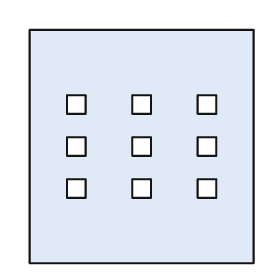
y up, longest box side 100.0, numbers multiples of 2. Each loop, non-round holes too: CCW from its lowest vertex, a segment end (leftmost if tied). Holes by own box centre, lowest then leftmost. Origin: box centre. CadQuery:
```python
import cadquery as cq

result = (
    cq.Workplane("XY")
    .moveTo(-48.0, -50.0)
    .lineTo(48.0, -50.0)
    .lineTo(48.0, 50.0)
    .lineTo(-48.0, 50.0)
    .close()
    .moveTo(-32.0, -22.0)
    .lineTo(-24.0, -22.0)
    .lineTo(-24.0, -14.0)
    .lineTo(-32.0, -14.0)
    .close()
    .moveTo(-4.0, -22.0)
    .lineTo(4.0, -22.0)
    .lineTo(4.0, -14.0)
    .lineTo(-4.0, -14.0)
    .close()
    .moveTo(24.0, -22.0)
    .lineTo(32.0, -22.0)
    .lineTo(32.0, -14.0)
    .lineTo(24.0, -14.0)
    .close()
    .moveTo(-32.0, -4.0)
    .lineTo(-24.0, -4.0)
    .lineTo(-24.0, 4.0)
    .lineTo(-32.0, 4.0)
    .close()
    .moveTo(-4.0, -4.0)
    .lineTo(4.0, -4.0)
    .lineTo(4.0, 4.0)
    .lineTo(-4.0, 4.0)
    .close()
    .moveTo(24.0, -4.0)
    .lineTo(32.0, -4.0)
    .lineTo(32.0, 4.0)
    .lineTo(24.0, 4.0)
    .close()
    .moveTo(-32.0, 14.0)
    .lineTo(-24.0, 14.0)
    .lineTo(-24.0, 22.0)
    .lineTo(-32.0, 22.0)
    .close()
    .moveTo(-4.0, 14.0)
    .lineTo(4.0, 14.0)
    .lineTo(4.0, 22.0)
    .lineTo(-4.0, 22.0)
    .close()
    .moveTo(24.0, 14.0)
    .lineTo(32.0, 14.0)
    .lineTo(32.0, 22.0)
    .lineTo(24.0, 22.0)
    .close()
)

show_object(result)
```